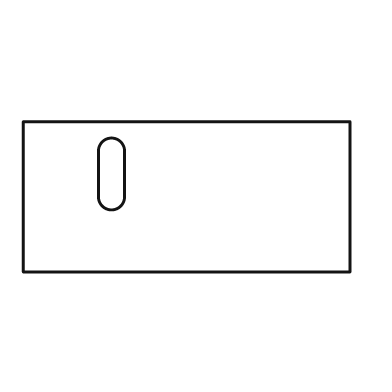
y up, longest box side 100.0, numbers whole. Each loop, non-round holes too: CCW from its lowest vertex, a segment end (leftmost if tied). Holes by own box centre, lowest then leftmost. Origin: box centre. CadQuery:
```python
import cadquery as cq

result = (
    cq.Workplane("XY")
    .moveTo(-50.0, -23.0)
    .lineTo(50.0, -23.0)
    .lineTo(50.0, 23.0)
    .lineTo(-50.0, 23.0)
    .close()
    .moveTo(-27.0, 0.0)
    .threePointArc((-23.0, -4.0), (-19.0, 0.0))
    .lineTo(-19.0, 14.0)
    .threePointArc((-23.0, 18.0), (-27.0, 14.0))
    .close()
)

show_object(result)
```